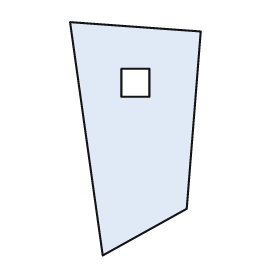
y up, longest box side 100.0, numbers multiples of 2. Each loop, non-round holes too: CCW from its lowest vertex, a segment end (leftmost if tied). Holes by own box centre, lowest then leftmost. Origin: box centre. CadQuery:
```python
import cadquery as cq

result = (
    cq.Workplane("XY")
    .moveTo(-14.0, -50.0)
    .lineTo(22.0, -30.0)
    .lineTo(28.0, 46.0)
    .lineTo(-28.0, 50.0)
    .close()
    .moveTo(-6.0, 18.0)
    .lineTo(6.0, 18.0)
    .lineTo(6.0, 30.0)
    .lineTo(-6.0, 30.0)
    .close()
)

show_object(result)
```